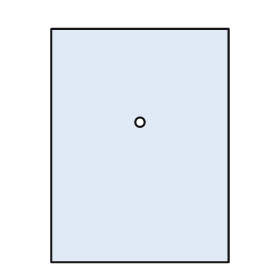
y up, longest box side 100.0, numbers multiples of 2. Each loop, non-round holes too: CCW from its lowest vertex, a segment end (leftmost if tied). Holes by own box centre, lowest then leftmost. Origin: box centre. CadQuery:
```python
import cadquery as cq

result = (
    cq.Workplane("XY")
    .moveTo(-38.0, -50.0)
    .lineTo(38.0, -50.0)
    .lineTo(38.0, 50.0)
    .lineTo(-38.0, 50.0)
    .close()
    .moveTo(0.0, 10.0)
    .circle(2.0)
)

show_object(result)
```